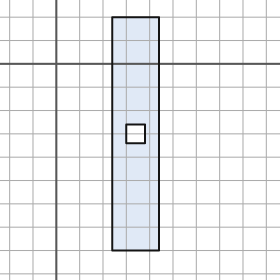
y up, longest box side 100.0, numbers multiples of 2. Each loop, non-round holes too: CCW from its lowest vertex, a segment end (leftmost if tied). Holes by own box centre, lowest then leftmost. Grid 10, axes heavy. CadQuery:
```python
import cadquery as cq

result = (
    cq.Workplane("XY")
    .moveTo(24.0, -80.0)
    .lineTo(44.0, -80.0)
    .lineTo(44.0, 20.0)
    .lineTo(24.0, 20.0)
    .close()
    .moveTo(30.0, -34.0)
    .lineTo(38.0, -34.0)
    .lineTo(38.0, -26.0)
    .lineTo(30.0, -26.0)
    .close()
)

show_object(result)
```